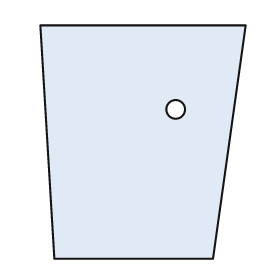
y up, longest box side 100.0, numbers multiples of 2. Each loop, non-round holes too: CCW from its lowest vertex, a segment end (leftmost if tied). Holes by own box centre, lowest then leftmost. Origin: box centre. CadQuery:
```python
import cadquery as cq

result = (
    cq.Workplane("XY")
    .moveTo(-38.0, -50.0)
    .lineTo(30.0, -50.0)
    .lineTo(44.0, 50.0)
    .lineTo(-44.0, 50.0)
    .close()
    .moveTo(14.0, 14.0)
    .circle(4.0)
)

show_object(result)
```